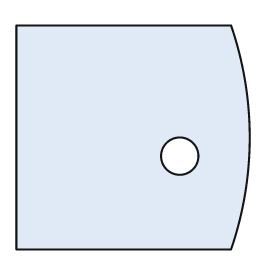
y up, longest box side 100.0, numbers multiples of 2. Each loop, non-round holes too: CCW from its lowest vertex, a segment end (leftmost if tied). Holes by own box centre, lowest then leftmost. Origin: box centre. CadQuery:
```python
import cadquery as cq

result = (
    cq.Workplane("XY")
    .moveTo(-50.0, -48.0)
    .lineTo(42.0, -48.0)
    .threePointArc((50.0, 0.0), (42.0, 48.0))
    .lineTo(-50.0, 48.0)
    .close()
    .moveTo(20.0, -8.0)
    .circle(8.0)
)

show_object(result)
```